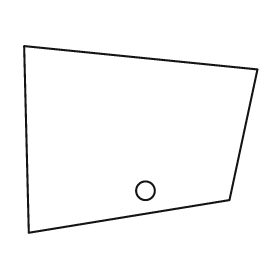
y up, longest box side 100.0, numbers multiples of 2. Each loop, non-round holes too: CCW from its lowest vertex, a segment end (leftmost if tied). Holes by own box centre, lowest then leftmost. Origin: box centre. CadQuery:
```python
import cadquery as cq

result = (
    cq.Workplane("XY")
    .moveTo(-48.0, -40.0)
    .lineTo(38.0, -26.0)
    .lineTo(50.0, 30.0)
    .lineTo(-50.0, 40.0)
    .close()
    .moveTo(2.0, -22.0)
    .circle(4.0)
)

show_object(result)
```